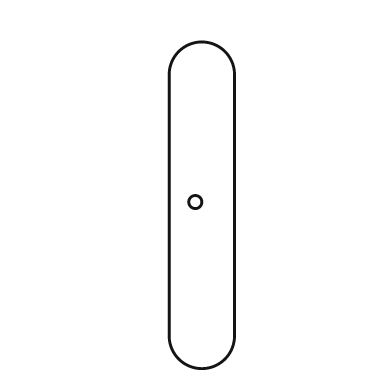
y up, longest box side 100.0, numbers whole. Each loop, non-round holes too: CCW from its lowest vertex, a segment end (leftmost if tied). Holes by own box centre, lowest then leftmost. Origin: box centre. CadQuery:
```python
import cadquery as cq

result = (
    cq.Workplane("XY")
    .moveTo(-10.0, -40.0)
    .threePointArc((0.0, -50.0), (10.0, -40.0))
    .lineTo(10.0, 40.0)
    .threePointArc((0.0, 50.0), (-10.0, 40.0))
    .close()
    .moveTo(-2.0, 1.0)
    .circle(2.0)
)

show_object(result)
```